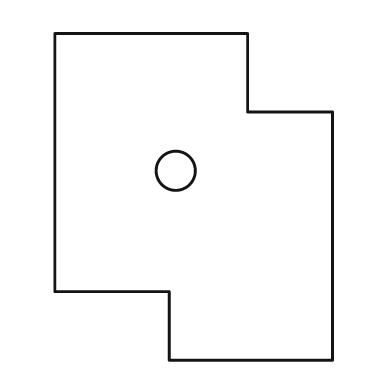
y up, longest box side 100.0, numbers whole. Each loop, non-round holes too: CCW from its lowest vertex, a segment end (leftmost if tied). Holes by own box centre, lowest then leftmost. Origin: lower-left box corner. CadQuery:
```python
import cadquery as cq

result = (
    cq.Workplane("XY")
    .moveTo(35.0, 0.0)
    .lineTo(85.0, 0.0)
    .lineTo(85.0, 76.0)
    .lineTo(59.0, 76.0)
    .lineTo(59.0, 100.0)
    .lineTo(0.0, 100.0)
    .lineTo(0.0, 21.0)
    .lineTo(35.0, 21.0)
    .close()
    .moveTo(37.0, 58.0)
    .circle(6.0)
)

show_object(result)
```